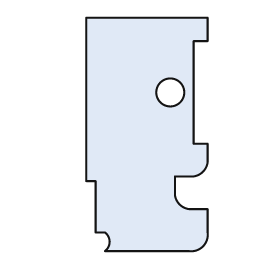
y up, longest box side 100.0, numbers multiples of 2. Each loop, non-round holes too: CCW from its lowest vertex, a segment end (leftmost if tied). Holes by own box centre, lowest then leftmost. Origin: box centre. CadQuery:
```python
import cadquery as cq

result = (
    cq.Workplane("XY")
    .moveTo(-18.0, -50.0)
    .lineTo(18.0, -50.0)
    .threePointArc((24.0, -48.0), (26.0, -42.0))
    .lineTo(26.0, -32.0)
    .lineTo(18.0, -32.0)
    .threePointArc((14.0, -30.0), (12.0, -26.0))
    .lineTo(12.0, -18.0)
    .lineTo(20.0, -18.0)
    .threePointArc((24.0, -16.0), (26.0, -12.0))
    .lineTo(26.0, -4.0)
    .lineTo(20.0, -4.0)
    .lineTo(20.0, 40.0)
    .lineTo(26.0, 40.0)
    .lineTo(26.0, 50.0)
    .lineTo(-26.0, 50.0)
    .lineTo(-26.0, -20.0)
    .lineTo(-22.0, -20.0)
    .lineTo(-22.0, -42.0)
    .lineTo(-18.0, -42.0)
    .threePointArc((-16.0, -46.0), (-18.0, -50.0))
    .close()
    .moveTo(10.0, 18.0)
    .circle(6.0)
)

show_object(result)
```